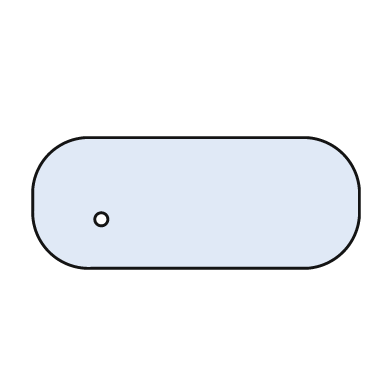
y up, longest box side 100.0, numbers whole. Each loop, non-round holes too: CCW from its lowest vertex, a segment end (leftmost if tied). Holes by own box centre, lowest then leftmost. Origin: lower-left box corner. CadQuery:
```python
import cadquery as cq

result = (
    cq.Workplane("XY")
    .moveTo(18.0, 0.0)
    .lineTo(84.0, 0.0)
    .threePointArc((95.0, 5.0), (100.0, 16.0))
    .lineTo(100.0, 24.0)
    .threePointArc((95.0, 35.0), (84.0, 40.0))
    .lineTo(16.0, 40.0)
    .threePointArc((5.0, 35.0), (0.0, 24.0))
    .lineTo(0.0, 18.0)
    .threePointArc((5.0, 5.0), (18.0, 0.0))
    .close()
    .moveTo(21.0, 15.0)
    .circle(2.0)
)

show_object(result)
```